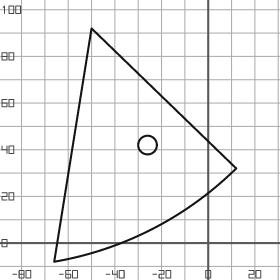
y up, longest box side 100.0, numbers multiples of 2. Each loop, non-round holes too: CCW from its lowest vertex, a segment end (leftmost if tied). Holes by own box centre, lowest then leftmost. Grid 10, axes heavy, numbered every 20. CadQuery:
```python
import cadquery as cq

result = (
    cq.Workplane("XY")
    .moveTo(-66.0, -8.0)
    .threePointArc((-24.0, 6.0), (12.0, 32.0))
    .lineTo(-50.0, 92.0)
    .close()
    .moveTo(-26.0, 42.0)
    .circle(4.0)
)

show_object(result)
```